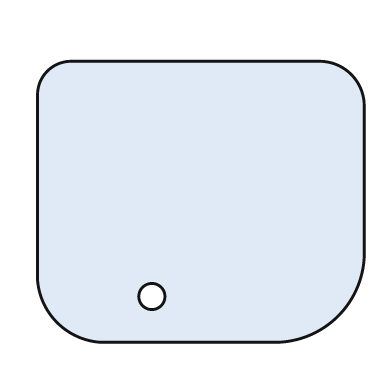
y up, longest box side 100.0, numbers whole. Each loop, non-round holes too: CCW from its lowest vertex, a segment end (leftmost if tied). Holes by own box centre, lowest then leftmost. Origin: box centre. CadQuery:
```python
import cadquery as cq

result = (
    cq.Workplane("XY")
    .moveTo(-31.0, -43.0)
    .lineTo(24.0, -43.0)
    .threePointArc((42.0, -35.0), (50.0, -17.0))
    .lineTo(50.0, 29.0)
    .threePointArc((46.0, 39.0), (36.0, 43.0))
    .lineTo(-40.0, 43.0)
    .threePointArc((-47.0, 40.0), (-50.0, 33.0))
    .lineTo(-50.0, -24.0)
    .threePointArc((-44.0, -37.0), (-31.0, -43.0))
    .close()
    .moveTo(-15.0, -29.0)
    .circle(4.0)
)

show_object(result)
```